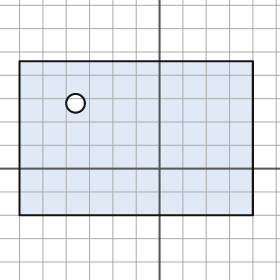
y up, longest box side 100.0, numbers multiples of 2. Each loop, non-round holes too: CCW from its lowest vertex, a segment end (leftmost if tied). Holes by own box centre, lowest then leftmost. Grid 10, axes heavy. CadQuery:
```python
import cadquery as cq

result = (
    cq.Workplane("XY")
    .moveTo(-60.0, -20.0)
    .lineTo(40.0, -20.0)
    .lineTo(40.0, 46.0)
    .lineTo(-60.0, 46.0)
    .close()
    .moveTo(-36.0, 28.0)
    .circle(4.0)
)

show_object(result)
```